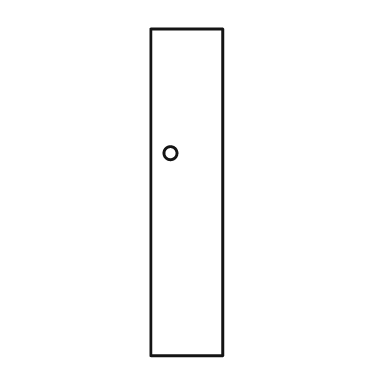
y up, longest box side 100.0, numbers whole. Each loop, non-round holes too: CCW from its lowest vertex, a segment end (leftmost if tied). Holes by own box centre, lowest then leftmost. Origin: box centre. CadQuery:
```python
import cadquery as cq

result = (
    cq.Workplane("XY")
    .moveTo(-11.0, -50.0)
    .lineTo(11.0, -50.0)
    .lineTo(11.0, 50.0)
    .lineTo(-11.0, 50.0)
    .close()
    .moveTo(-5.0, 12.0)
    .circle(2.0)
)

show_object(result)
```